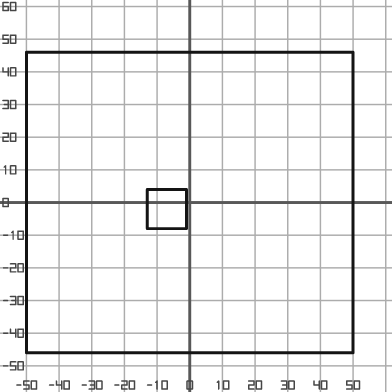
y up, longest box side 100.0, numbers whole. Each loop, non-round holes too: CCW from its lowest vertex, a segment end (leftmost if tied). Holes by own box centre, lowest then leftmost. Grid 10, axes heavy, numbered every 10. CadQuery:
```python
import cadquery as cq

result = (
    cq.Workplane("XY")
    .moveTo(-50.0, -46.0)
    .lineTo(50.0, -46.0)
    .lineTo(50.0, 46.0)
    .lineTo(-50.0, 46.0)
    .close()
    .moveTo(-13.0, -8.0)
    .lineTo(-1.0, -8.0)
    .lineTo(-1.0, 4.0)
    .lineTo(-13.0, 4.0)
    .close()
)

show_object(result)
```